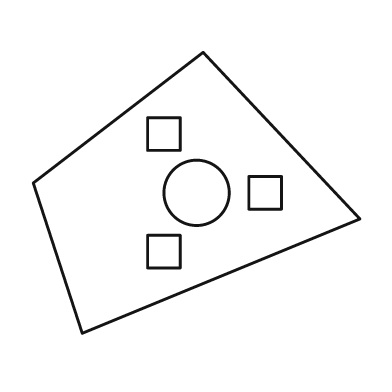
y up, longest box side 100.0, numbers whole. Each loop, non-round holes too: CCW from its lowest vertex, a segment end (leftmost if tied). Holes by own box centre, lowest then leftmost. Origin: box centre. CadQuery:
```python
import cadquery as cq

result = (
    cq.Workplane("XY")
    .moveTo(-35.0, -43.0)
    .lineTo(50.0, -8.0)
    .lineTo(2.0, 43.0)
    .lineTo(-50.0, 3.0)
    .close()
    .moveTo(-15.0, -23.0)
    .lineTo(-5.0, -23.0)
    .lineTo(-5.0, -13.0)
    .lineTo(-15.0, -13.0)
    .close()
    .moveTo(0.0, 0.0)
    .circle(10.0)
    .moveTo(16.0, -5.0)
    .lineTo(26.0, -5.0)
    .lineTo(26.0, 5.0)
    .lineTo(16.0, 5.0)
    .close()
    .moveTo(-15.0, 13.0)
    .lineTo(-5.0, 13.0)
    .lineTo(-5.0, 23.0)
    .lineTo(-15.0, 23.0)
    .close()
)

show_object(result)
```